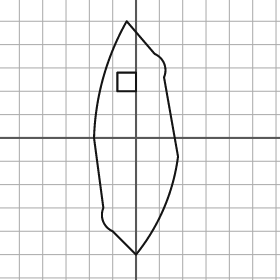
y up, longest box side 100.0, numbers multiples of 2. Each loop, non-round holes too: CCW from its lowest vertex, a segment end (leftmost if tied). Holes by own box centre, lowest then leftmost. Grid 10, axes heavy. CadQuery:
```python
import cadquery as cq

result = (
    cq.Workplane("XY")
    .moveTo(0.0, -50.0)
    .threePointArc((12.0, -30.0), (18.0, -8.0))
    .lineTo(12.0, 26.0)
    .threePointArc((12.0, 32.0), (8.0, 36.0))
    .lineTo(-4.0, 50.0)
    .threePointArc((-14.0, 26.0), (-18.0, 0.0))
    .lineTo(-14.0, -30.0)
    .threePointArc((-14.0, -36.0), (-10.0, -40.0))
    .close()
    .moveTo(-8.0, 20.0)
    .lineTo(0.0, 20.0)
    .lineTo(0.0, 28.0)
    .lineTo(-8.0, 28.0)
    .close()
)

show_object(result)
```